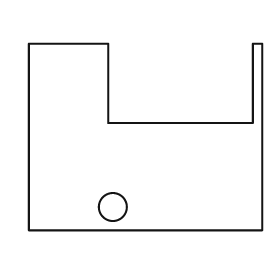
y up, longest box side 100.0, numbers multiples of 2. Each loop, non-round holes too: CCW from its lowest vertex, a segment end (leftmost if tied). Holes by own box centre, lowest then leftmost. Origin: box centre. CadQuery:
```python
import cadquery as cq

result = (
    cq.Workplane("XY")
    .moveTo(-50.0, -40.0)
    .lineTo(50.0, -40.0)
    .lineTo(50.0, 40.0)
    .lineTo(46.0, 40.0)
    .lineTo(46.0, 6.0)
    .lineTo(-16.0, 6.0)
    .lineTo(-16.0, 40.0)
    .lineTo(-50.0, 40.0)
    .close()
    .moveTo(-14.0, -30.0)
    .circle(6.0)
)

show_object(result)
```